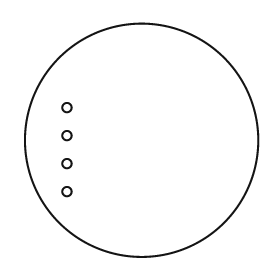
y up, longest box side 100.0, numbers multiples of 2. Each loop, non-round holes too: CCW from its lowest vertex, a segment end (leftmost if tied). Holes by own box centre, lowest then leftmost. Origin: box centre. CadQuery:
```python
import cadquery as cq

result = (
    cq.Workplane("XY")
    .moveTo(0.0, 0.0)
    .circle(50.0)
    .moveTo(-32.0, -22.0)
    .circle(2.0)
    .moveTo(-32.0, -10.0)
    .circle(2.0)
    .moveTo(-32.0, 2.0)
    .circle(2.0)
    .moveTo(-32.0, 14.0)
    .circle(2.0)
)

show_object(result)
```